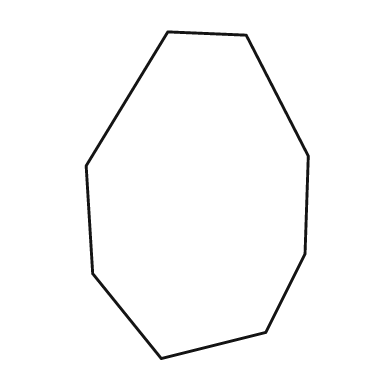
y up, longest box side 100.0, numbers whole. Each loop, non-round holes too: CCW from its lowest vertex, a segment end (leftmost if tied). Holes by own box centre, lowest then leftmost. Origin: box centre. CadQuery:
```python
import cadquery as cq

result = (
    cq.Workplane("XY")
    .moveTo(-11.0, -50.0)
    .lineTo(21.0, -42.0)
    .lineTo(33.0, -18.0)
    .lineTo(34.0, 12.0)
    .lineTo(15.0, 49.0)
    .lineTo(-9.0, 50.0)
    .lineTo(-34.0, 9.0)
    .lineTo(-32.0, -24.0)
    .close()
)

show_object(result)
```